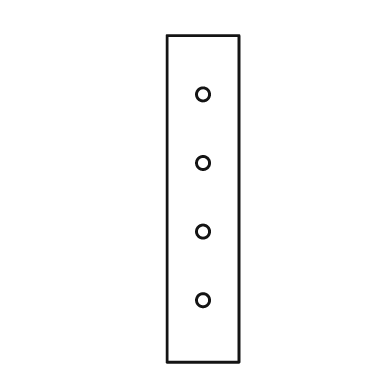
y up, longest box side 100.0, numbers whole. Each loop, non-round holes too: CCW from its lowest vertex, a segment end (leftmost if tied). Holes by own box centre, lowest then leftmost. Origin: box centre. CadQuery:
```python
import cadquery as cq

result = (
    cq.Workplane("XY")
    .moveTo(-11.0, -50.0)
    .lineTo(11.0, -50.0)
    .lineTo(11.0, 50.0)
    .lineTo(-11.0, 50.0)
    .close()
    .moveTo(0.0, -31.0)
    .circle(2.0)
    .moveTo(0.0, -10.0)
    .circle(2.0)
    .moveTo(0.0, 11.0)
    .circle(2.0)
    .moveTo(0.0, 32.0)
    .circle(2.0)
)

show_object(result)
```